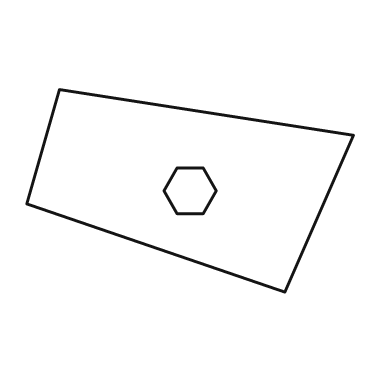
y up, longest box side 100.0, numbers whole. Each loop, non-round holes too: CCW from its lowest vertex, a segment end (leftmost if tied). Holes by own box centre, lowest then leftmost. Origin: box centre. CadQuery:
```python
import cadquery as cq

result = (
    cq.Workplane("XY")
    .moveTo(29.0, -31.0)
    .lineTo(50.0, 17.0)
    .lineTo(-40.0, 31.0)
    .lineTo(-50.0, -4.0)
    .close()
    .moveTo(-4.0, -7.0)
    .lineTo(4.0, -7.0)
    .lineTo(8.0, 0.0)
    .lineTo(4.0, 7.0)
    .lineTo(-4.0, 7.0)
    .lineTo(-8.0, 0.0)
    .close()
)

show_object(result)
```